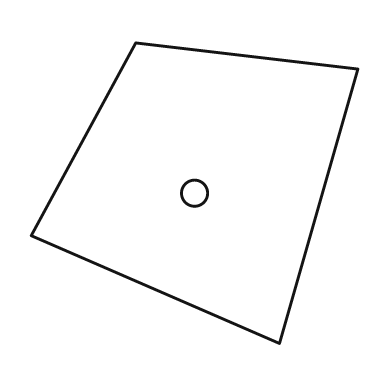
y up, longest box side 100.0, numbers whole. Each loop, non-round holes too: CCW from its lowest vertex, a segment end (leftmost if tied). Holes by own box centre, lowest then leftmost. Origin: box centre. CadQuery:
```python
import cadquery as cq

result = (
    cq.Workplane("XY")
    .moveTo(26.0, -46.0)
    .lineTo(50.0, 38.0)
    .lineTo(-18.0, 46.0)
    .lineTo(-50.0, -13.0)
    .close()
    .moveTo(0.0, 0.0)
    .circle(4.0)
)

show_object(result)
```